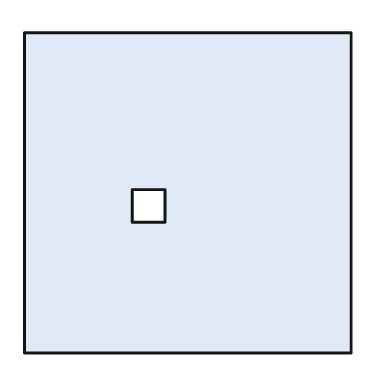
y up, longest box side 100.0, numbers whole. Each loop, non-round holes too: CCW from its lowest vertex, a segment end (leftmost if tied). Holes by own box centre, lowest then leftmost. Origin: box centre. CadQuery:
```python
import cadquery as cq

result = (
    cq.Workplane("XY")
    .moveTo(-50.0, -49.0)
    .lineTo(50.0, -49.0)
    .lineTo(50.0, 49.0)
    .lineTo(-50.0, 49.0)
    .close()
    .moveTo(-17.0, -9.0)
    .lineTo(-7.0, -9.0)
    .lineTo(-7.0, 1.0)
    .lineTo(-17.0, 1.0)
    .close()
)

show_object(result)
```